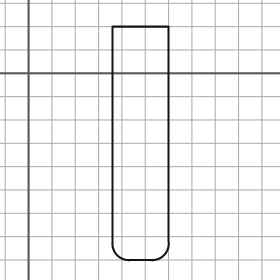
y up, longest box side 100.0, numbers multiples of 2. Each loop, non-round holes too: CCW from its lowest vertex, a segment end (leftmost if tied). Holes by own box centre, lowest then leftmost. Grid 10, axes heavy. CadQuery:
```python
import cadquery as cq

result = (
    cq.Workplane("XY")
    .moveTo(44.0, -80.0)
    .lineTo(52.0, -80.0)
    .threePointArc((58.0, -78.0), (60.0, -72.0))
    .lineTo(60.0, 20.0)
    .lineTo(36.0, 20.0)
    .lineTo(36.0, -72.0)
    .threePointArc((38.0, -78.0), (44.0, -80.0))
    .close()
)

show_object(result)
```